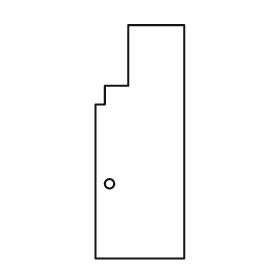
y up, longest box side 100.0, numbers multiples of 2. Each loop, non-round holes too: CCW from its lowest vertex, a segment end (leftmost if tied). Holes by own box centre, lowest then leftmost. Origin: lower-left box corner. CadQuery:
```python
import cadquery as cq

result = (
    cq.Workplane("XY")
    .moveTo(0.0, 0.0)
    .lineTo(38.0, 0.0)
    .lineTo(38.0, 100.0)
    .lineTo(14.0, 100.0)
    .lineTo(14.0, 74.0)
    .lineTo(4.0, 74.0)
    .lineTo(4.0, 66.0)
    .lineTo(0.0, 66.0)
    .close()
    .moveTo(6.0, 32.0)
    .circle(2.0)
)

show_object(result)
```